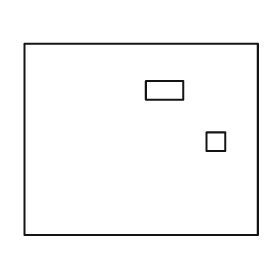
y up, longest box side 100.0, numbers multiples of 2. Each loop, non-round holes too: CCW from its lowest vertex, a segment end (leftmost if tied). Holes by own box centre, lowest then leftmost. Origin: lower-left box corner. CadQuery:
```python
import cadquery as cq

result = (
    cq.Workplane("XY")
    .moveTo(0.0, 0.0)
    .lineTo(100.0, 0.0)
    .lineTo(100.0, 82.0)
    .lineTo(0.0, 82.0)
    .close()
    .moveTo(78.0, 36.0)
    .lineTo(86.0, 36.0)
    .lineTo(86.0, 44.0)
    .lineTo(78.0, 44.0)
    .close()
    .moveTo(52.0, 58.0)
    .lineTo(68.0, 58.0)
    .lineTo(68.0, 66.0)
    .lineTo(52.0, 66.0)
    .close()
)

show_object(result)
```